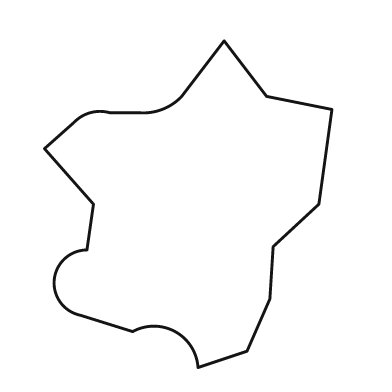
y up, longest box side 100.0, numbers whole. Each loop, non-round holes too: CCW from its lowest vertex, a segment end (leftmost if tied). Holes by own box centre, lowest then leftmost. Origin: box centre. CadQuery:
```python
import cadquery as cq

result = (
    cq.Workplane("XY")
    .moveTo(3.0, -50.0)
    .lineTo(18.0, -45.0)
    .lineTo(25.0, -29.0)
    .lineTo(26.0, -13.0)
    .lineTo(40.0, 0.0)
    .lineTo(44.0, 29.0)
    .lineTo(24.0, 33.0)
    .lineTo(11.0, 50.0)
    .lineTo(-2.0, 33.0)
    .threePointArc((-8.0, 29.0), (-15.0, 28.0))
    .lineTo(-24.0, 28.0)
    .threePointArc((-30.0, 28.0), (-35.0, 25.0))
    .lineTo(-44.0, 17.0)
    .lineTo(-29.0, 0.0)
    .lineTo(-31.0, -14.0)
    .threePointArc((-41.0, -23.0), (-33.0, -34.0))
    .lineTo(-17.0, -39.0)
    .threePointArc((-4.0, -39.0), (3.0, -50.0))
    .close()
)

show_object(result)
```